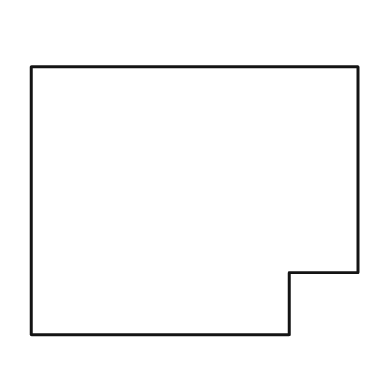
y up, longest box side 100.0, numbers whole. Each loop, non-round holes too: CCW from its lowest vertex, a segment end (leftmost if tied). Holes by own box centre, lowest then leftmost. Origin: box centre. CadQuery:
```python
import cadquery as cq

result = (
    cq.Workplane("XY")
    .moveTo(-50.0, -41.0)
    .lineTo(29.0, -41.0)
    .lineTo(29.0, -22.0)
    .lineTo(50.0, -22.0)
    .lineTo(50.0, 41.0)
    .lineTo(-50.0, 41.0)
    .close()
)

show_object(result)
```